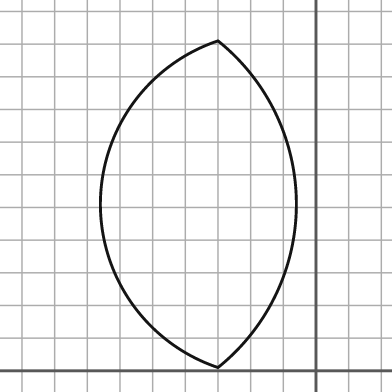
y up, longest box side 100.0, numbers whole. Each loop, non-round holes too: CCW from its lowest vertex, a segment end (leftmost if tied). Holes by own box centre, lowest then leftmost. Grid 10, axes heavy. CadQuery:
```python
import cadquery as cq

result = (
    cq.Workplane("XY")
    .moveTo(-30.0, 1.0)
    .threePointArc((-6.0, 51.0), (-30.0, 101.0))
    .threePointArc((-66.0, 51.0), (-30.0, 1.0))
    .close()
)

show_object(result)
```